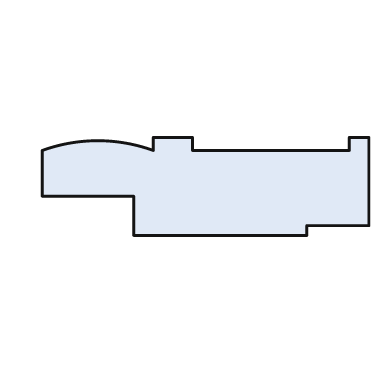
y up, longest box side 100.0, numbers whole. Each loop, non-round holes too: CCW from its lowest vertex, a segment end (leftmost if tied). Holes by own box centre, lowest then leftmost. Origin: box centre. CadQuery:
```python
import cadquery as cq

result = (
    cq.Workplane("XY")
    .moveTo(-22.0, -15.0)
    .lineTo(31.0, -15.0)
    .lineTo(31.0, -12.0)
    .lineTo(50.0, -12.0)
    .lineTo(50.0, 15.0)
    .lineTo(44.0, 15.0)
    .lineTo(44.0, 11.0)
    .lineTo(-4.0, 11.0)
    .lineTo(-4.0, 15.0)
    .lineTo(-16.0, 15.0)
    .lineTo(-16.0, 11.0)
    .threePointArc((-33.0, 14.0), (-50.0, 11.0))
    .lineTo(-50.0, -3.0)
    .lineTo(-22.0, -3.0)
    .close()
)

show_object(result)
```